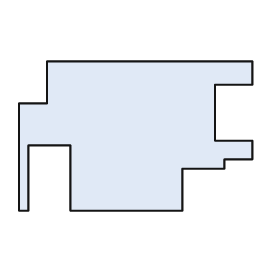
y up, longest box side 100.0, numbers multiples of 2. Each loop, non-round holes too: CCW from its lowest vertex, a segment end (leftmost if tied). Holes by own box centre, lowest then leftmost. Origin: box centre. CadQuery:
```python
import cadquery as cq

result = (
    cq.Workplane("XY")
    .moveTo(-50.0, -32.0)
    .lineTo(-46.0, -32.0)
    .lineTo(-46.0, -4.0)
    .lineTo(-28.0, -4.0)
    .lineTo(-28.0, -32.0)
    .lineTo(20.0, -32.0)
    .lineTo(20.0, -14.0)
    .lineTo(38.0, -14.0)
    .lineTo(38.0, -10.0)
    .lineTo(50.0, -10.0)
    .lineTo(50.0, -2.0)
    .lineTo(34.0, -2.0)
    .lineTo(34.0, 22.0)
    .lineTo(50.0, 22.0)
    .lineTo(50.0, 32.0)
    .lineTo(-38.0, 32.0)
    .lineTo(-38.0, 14.0)
    .lineTo(-50.0, 14.0)
    .close()
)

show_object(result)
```